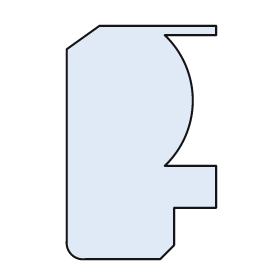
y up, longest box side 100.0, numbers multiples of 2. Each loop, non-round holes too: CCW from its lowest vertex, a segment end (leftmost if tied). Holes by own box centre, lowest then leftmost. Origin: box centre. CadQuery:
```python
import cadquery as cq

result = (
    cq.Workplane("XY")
    .moveTo(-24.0, -50.0)
    .lineTo(8.0, -50.0)
    .lineTo(14.0, -44.0)
    .lineTo(14.0, -28.0)
    .lineTo(32.0, -28.0)
    .lineTo(32.0, -10.0)
    .lineTo(10.0, -10.0)
    .threePointArc((22.0, 18.0), (10.0, 46.0))
    .lineTo(32.0, 46.0)
    .lineTo(32.0, 50.0)
    .lineTo(-18.0, 50.0)
    .lineTo(-32.0, 40.0)
    .lineTo(-32.0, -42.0)
    .threePointArc((-30.0, -48.0), (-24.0, -50.0))
    .close()
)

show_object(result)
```